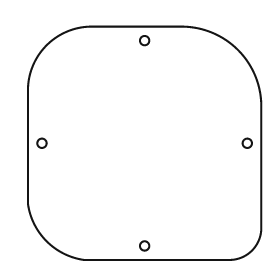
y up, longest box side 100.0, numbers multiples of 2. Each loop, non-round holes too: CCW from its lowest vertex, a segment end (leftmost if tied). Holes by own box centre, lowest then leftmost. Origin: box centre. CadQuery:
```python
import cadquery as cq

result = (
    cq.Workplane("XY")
    .moveTo(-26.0, -50.0)
    .lineTo(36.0, -50.0)
    .threePointArc((46.0, -46.0), (50.0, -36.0))
    .lineTo(50.0, 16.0)
    .threePointArc((40.0, 40.0), (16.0, 50.0))
    .lineTo(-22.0, 50.0)
    .threePointArc((-42.0, 42.0), (-50.0, 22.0))
    .lineTo(-50.0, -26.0)
    .threePointArc((-42.0, -42.0), (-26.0, -50.0))
    .close()
    .moveTo(0.0, -44.0)
    .circle(2.0)
    .moveTo(-44.0, 0.0)
    .circle(2.0)
    .moveTo(44.0, 0.0)
    .circle(2.0)
    .moveTo(0.0, 44.0)
    .circle(2.0)
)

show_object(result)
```